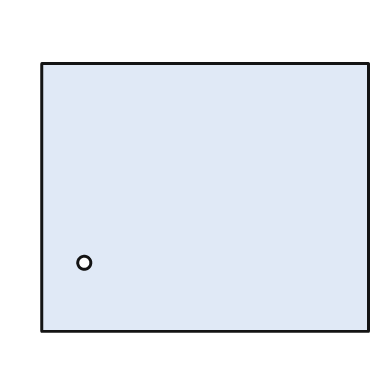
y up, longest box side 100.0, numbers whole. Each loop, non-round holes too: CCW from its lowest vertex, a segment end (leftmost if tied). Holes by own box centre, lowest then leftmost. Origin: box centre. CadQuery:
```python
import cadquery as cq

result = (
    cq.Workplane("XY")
    .moveTo(-50.0, -41.0)
    .lineTo(50.0, -41.0)
    .lineTo(50.0, 41.0)
    .lineTo(-50.0, 41.0)
    .close()
    .moveTo(-37.0, -20.0)
    .circle(2.0)
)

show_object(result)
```